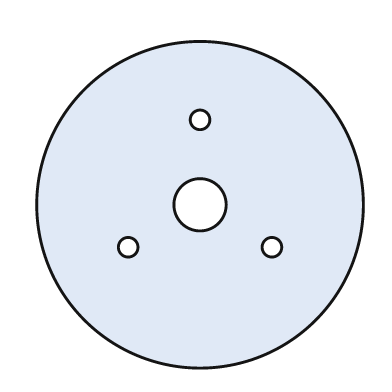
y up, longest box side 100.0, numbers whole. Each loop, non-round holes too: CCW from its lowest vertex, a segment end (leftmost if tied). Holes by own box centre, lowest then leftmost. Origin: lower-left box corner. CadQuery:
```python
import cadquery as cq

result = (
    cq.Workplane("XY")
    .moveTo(50.0, 50.0)
    .circle(50.0)
    .moveTo(28.0, 37.0)
    .circle(3.0)
    .moveTo(72.0, 37.0)
    .circle(3.0)
    .moveTo(50.0, 50.0)
    .circle(8.0)
    .moveTo(50.0, 76.0)
    .circle(3.0)
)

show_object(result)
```